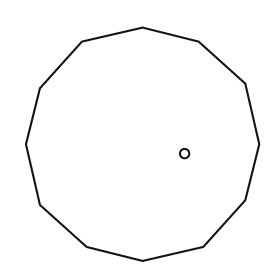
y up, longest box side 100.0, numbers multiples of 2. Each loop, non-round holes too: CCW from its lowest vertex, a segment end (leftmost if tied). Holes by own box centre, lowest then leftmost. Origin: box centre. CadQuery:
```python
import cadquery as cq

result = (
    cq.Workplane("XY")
    .moveTo(0.0, -50.0)
    .lineTo(26.0, -44.0)
    .lineTo(44.0, -24.0)
    .lineTo(50.0, 0.0)
    .lineTo(44.0, 26.0)
    .lineTo(24.0, 44.0)
    .lineTo(0.0, 50.0)
    .lineTo(-26.0, 44.0)
    .lineTo(-44.0, 24.0)
    .lineTo(-50.0, 0.0)
    .lineTo(-44.0, -26.0)
    .lineTo(-24.0, -44.0)
    .close()
    .moveTo(18.0, -4.0)
    .circle(2.0)
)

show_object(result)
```